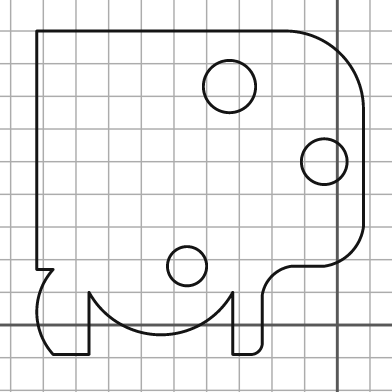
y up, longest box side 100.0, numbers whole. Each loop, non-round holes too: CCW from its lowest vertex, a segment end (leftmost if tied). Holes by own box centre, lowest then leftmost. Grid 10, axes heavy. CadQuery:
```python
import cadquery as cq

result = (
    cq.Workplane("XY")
    .moveTo(-87.0, -9.0)
    .lineTo(-76.0, -9.0)
    .lineTo(-76.0, 10.0)
    .threePointArc((-54.0, -3.0), (-32.0, 10.0))
    .lineTo(-32.0, -9.0)
    .lineTo(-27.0, -9.0)
    .threePointArc((-24.0, -8.0), (-23.0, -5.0))
    .lineTo(-23.0, 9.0)
    .threePointArc((-20.0, 15.0), (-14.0, 18.0))
    .lineTo(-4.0, 18.0)
    .threePointArc((4.0, 22.0), (8.0, 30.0))
    .lineTo(8.0, 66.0)
    .threePointArc((1.0, 83.0), (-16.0, 90.0))
    .lineTo(-92.0, 90.0)
    .lineTo(-92.0, 17.0)
    .lineTo(-87.0, 17.0)
    .threePointArc((-92.0, 4.0), (-87.0, -9.0))
    .close()
    .moveTo(-46.0, 18.0)
    .circle(6.0)
    .moveTo(-4.0, 50.0)
    .circle(7.0)
    .moveTo(-33.0, 73.0)
    .circle(8.0)
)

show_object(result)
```